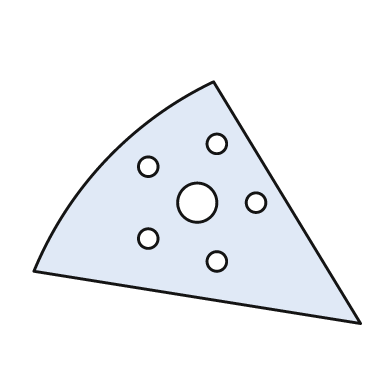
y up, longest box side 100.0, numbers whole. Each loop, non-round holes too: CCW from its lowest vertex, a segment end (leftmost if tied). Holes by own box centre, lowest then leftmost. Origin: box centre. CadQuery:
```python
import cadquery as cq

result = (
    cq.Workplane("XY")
    .moveTo(50.0, -37.0)
    .lineTo(5.0, 37.0)
    .threePointArc((-28.0, 13.0), (-50.0, -21.0))
    .close()
    .moveTo(6.0, -18.0)
    .circle(3.0)
    .moveTo(-15.0, -11.0)
    .circle(3.0)
    .moveTo(0.0, 0.0)
    .circle(6.0)
    .moveTo(18.0, 0.0)
    .circle(3.0)
    .moveTo(-15.0, 11.0)
    .circle(3.0)
    .moveTo(6.0, 18.0)
    .circle(3.0)
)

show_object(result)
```